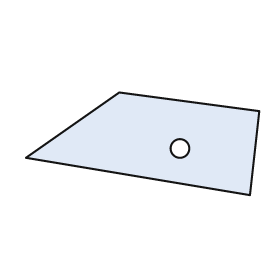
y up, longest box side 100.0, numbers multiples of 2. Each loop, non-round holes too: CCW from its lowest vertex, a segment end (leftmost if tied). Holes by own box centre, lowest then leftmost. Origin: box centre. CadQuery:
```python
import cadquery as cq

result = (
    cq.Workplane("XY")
    .moveTo(46.0, -22.0)
    .lineTo(50.0, 14.0)
    .lineTo(-10.0, 22.0)
    .lineTo(-50.0, -6.0)
    .close()
    .moveTo(16.0, -2.0)
    .circle(4.0)
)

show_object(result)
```